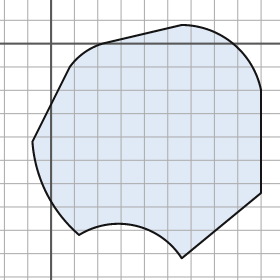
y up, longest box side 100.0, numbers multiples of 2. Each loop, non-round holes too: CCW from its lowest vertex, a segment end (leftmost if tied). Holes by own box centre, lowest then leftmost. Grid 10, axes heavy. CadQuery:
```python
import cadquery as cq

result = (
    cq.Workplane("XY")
    .moveTo(56.0, -92.0)
    .lineTo(90.0, -64.0)
    .lineTo(90.0, -20.0)
    .threePointArc((78.0, 0.0), (56.0, 8.0))
    .lineTo(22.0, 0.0)
    .threePointArc((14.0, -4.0), (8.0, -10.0))
    .lineTo(-8.0, -42.0)
    .threePointArc((-2.0, -64.0), (12.0, -82.0))
    .threePointArc((36.0, -78.0), (56.0, -92.0))
    .close()
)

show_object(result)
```